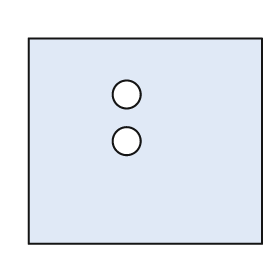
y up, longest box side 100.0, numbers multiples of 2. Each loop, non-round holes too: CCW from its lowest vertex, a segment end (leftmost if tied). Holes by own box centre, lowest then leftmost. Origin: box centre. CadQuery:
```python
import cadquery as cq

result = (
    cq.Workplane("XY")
    .moveTo(-50.0, -44.0)
    .lineTo(50.0, -44.0)
    .lineTo(50.0, 44.0)
    .lineTo(-50.0, 44.0)
    .close()
    .moveTo(-8.0, 0.0)
    .circle(6.0)
    .moveTo(-8.0, 20.0)
    .circle(6.0)
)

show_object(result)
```